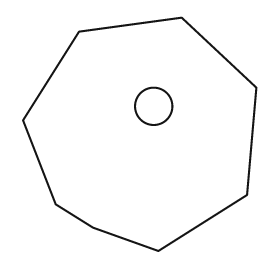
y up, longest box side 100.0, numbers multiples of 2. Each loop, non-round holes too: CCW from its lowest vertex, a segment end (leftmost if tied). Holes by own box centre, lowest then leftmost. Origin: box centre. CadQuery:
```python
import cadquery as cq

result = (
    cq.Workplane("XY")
    .moveTo(8.0, -50.0)
    .lineTo(46.0, -26.0)
    .lineTo(50.0, 20.0)
    .lineTo(18.0, 50.0)
    .lineTo(-26.0, 44.0)
    .lineTo(-50.0, 6.0)
    .lineTo(-36.0, -30.0)
    .lineTo(-20.0, -40.0)
    .close()
    .moveTo(6.0, 12.0)
    .circle(8.0)
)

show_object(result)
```